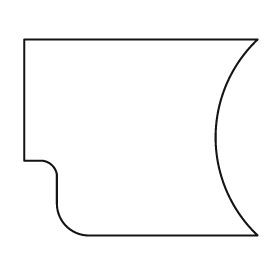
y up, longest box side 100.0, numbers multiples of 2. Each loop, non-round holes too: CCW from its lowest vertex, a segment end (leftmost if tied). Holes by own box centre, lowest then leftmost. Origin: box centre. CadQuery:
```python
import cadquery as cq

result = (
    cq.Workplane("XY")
    .moveTo(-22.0, -42.0)
    .lineTo(50.0, -42.0)
    .threePointArc((32.0, 0.0), (50.0, 42.0))
    .lineTo(-50.0, 42.0)
    .lineTo(-50.0, -10.0)
    .lineTo(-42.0, -10.0)
    .threePointArc((-38.0, -12.0), (-36.0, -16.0))
    .lineTo(-36.0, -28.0)
    .threePointArc((-32.0, -38.0), (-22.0, -42.0))
    .close()
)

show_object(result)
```